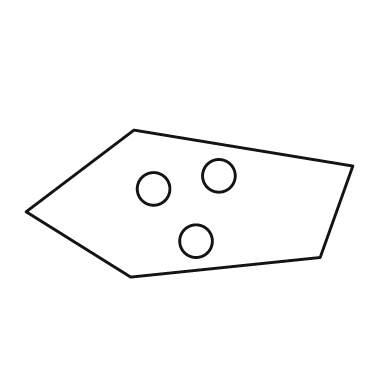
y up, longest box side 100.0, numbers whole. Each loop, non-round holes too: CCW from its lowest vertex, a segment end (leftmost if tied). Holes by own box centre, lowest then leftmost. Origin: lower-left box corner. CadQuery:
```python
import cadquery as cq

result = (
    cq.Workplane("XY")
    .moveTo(32.0, 0.0)
    .lineTo(90.0, 6.0)
    .lineTo(100.0, 34.0)
    .lineTo(33.0, 45.0)
    .lineTo(0.0, 20.0)
    .close()
    .moveTo(52.0, 11.0)
    .circle(5.0)
    .moveTo(39.0, 27.0)
    .circle(5.0)
    .moveTo(59.0, 31.0)
    .circle(5.0)
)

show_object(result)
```